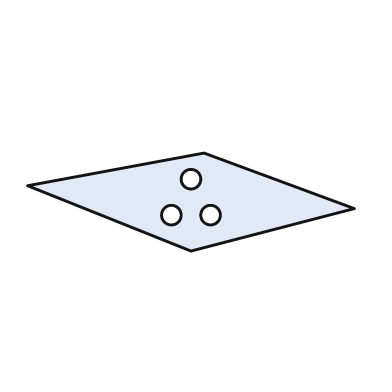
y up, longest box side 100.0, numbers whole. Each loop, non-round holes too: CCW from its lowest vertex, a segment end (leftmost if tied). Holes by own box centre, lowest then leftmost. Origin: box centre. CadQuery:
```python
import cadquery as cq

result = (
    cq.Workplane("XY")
    .moveTo(0.0, -15.0)
    .lineTo(50.0, -2.0)
    .lineTo(4.0, 15.0)
    .lineTo(-50.0, 5.0)
    .close()
    .moveTo(-6.0, -4.0)
    .circle(3.0)
    .moveTo(6.0, -4.0)
    .circle(3.0)
    .moveTo(0.0, 7.0)
    .circle(3.0)
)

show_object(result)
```